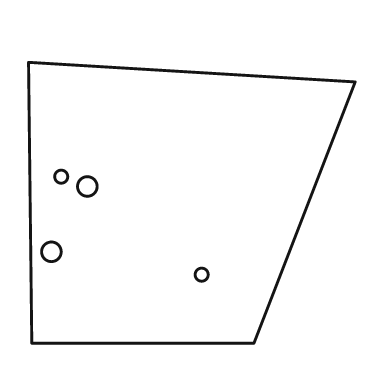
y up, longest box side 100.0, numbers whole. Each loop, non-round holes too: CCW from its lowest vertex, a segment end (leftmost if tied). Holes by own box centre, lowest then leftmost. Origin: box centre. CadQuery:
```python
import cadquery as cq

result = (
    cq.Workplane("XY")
    .moveTo(-49.0, -43.0)
    .lineTo(19.0, -43.0)
    .lineTo(50.0, 37.0)
    .lineTo(-50.0, 43.0)
    .close()
    .moveTo(3.0, -22.0)
    .circle(2.0)
    .moveTo(-43.0, -15.0)
    .circle(3.0)
    .moveTo(-32.0, 5.0)
    .circle(3.0)
    .moveTo(-40.0, 8.0)
    .circle(2.0)
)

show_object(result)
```